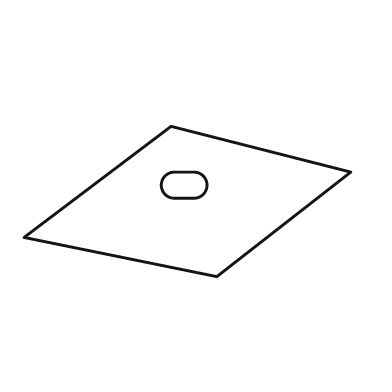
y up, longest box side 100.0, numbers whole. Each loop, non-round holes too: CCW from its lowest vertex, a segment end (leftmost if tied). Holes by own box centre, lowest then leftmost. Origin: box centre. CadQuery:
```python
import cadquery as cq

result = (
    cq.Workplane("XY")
    .moveTo(9.0, -23.0)
    .lineTo(50.0, 9.0)
    .lineTo(-5.0, 23.0)
    .lineTo(-50.0, -11.0)
    .close()
    .moveTo(-4.0, 1.0)
    .lineTo(2.0, 1.0)
    .threePointArc((6.0, 5.0), (2.0, 9.0))
    .lineTo(-4.0, 9.0)
    .threePointArc((-8.0, 5.0), (-4.0, 1.0))
    .close()
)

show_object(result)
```